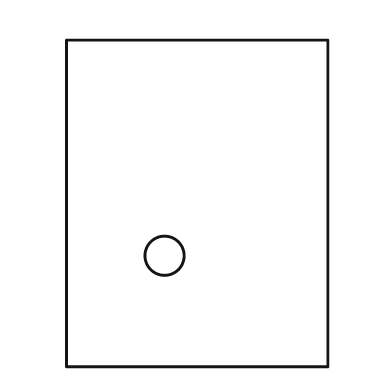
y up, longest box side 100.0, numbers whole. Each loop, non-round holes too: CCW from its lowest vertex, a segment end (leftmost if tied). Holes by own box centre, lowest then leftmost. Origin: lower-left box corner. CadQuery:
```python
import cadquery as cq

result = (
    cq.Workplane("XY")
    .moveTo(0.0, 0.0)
    .lineTo(80.0, 0.0)
    .lineTo(80.0, 100.0)
    .lineTo(0.0, 100.0)
    .close()
    .moveTo(30.0, 34.0)
    .circle(6.0)
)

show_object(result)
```